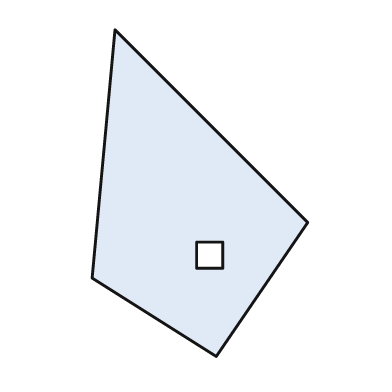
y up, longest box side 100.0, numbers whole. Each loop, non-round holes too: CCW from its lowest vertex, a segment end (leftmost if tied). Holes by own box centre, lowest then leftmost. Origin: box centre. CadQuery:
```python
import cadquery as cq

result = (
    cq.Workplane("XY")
    .moveTo(5.0, -50.0)
    .lineTo(33.0, -9.0)
    .lineTo(-26.0, 50.0)
    .lineTo(-33.0, -26.0)
    .close()
    .moveTo(-1.0, -23.0)
    .lineTo(7.0, -23.0)
    .lineTo(7.0, -15.0)
    .lineTo(-1.0, -15.0)
    .close()
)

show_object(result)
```